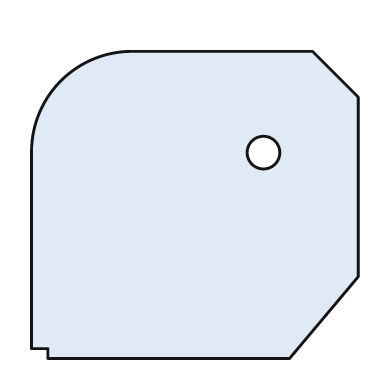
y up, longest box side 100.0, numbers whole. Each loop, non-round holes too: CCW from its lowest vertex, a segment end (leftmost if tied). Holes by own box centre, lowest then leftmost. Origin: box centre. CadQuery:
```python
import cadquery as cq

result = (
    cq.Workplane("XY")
    .moveTo(-45.0, -47.0)
    .lineTo(29.0, -47.0)
    .lineTo(50.0, -22.0)
    .lineTo(50.0, 33.0)
    .lineTo(36.0, 47.0)
    .lineTo(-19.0, 47.0)
    .threePointArc((-41.0, 38.0), (-50.0, 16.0))
    .lineTo(-50.0, -44.0)
    .lineTo(-45.0, -44.0)
    .close()
    .moveTo(21.0, 16.0)
    .circle(5.0)
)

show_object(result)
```